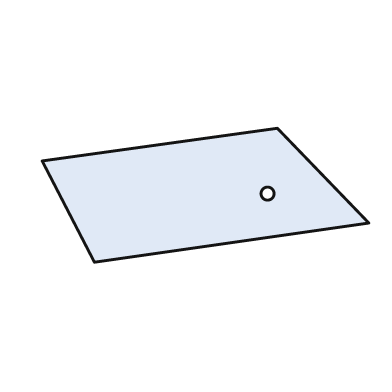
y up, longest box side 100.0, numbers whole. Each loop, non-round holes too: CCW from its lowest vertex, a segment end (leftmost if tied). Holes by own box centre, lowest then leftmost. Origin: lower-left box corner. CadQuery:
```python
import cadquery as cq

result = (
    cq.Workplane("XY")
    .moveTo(16.0, 0.0)
    .lineTo(100.0, 12.0)
    .lineTo(72.0, 41.0)
    .lineTo(0.0, 31.0)
    .close()
    .moveTo(69.0, 21.0)
    .circle(2.0)
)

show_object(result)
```